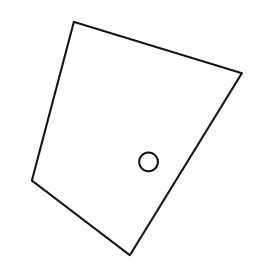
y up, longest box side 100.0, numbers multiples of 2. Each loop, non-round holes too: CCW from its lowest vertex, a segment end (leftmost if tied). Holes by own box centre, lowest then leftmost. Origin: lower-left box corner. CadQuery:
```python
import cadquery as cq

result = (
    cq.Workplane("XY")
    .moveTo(42.0, 0.0)
    .lineTo(90.0, 78.0)
    .lineTo(18.0, 100.0)
    .lineTo(0.0, 32.0)
    .close()
    .moveTo(50.0, 40.0)
    .circle(4.0)
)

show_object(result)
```